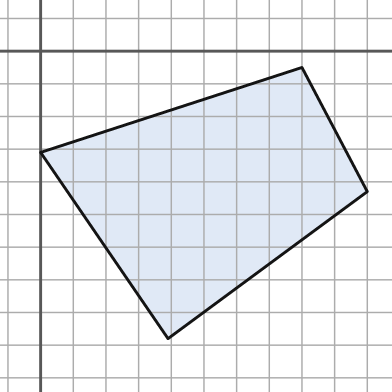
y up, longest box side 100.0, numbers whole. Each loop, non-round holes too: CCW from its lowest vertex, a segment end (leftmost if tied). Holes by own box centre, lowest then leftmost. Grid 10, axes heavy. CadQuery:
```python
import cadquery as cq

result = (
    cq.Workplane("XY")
    .moveTo(39.0, -88.0)
    .lineTo(100.0, -43.0)
    .lineTo(80.0, -5.0)
    .lineTo(0.0, -31.0)
    .close()
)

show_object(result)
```